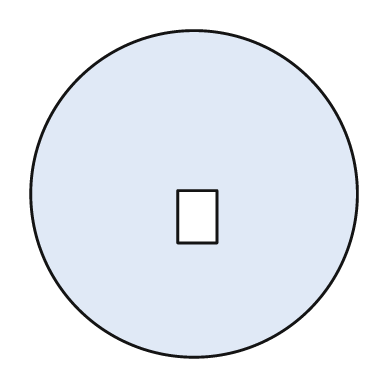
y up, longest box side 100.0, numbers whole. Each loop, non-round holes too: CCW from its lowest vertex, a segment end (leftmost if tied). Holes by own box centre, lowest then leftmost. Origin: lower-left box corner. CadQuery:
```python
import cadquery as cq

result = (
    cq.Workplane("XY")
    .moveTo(50.0, 50.0)
    .circle(50.0)
    .moveTo(45.0, 35.0)
    .lineTo(57.0, 35.0)
    .lineTo(57.0, 51.0)
    .lineTo(45.0, 51.0)
    .close()
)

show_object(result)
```